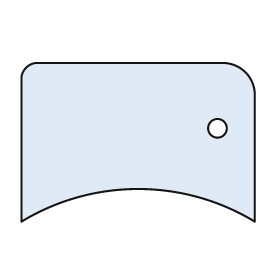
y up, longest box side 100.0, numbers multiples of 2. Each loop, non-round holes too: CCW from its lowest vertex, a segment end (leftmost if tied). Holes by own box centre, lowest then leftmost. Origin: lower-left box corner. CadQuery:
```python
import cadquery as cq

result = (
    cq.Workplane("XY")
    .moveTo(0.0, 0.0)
    .threePointArc((50.0, 14.0), (100.0, 0.0))
    .lineTo(100.0, 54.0)
    .threePointArc((96.0, 64.0), (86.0, 68.0))
    .lineTo(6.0, 68.0)
    .threePointArc((2.0, 66.0), (0.0, 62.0))
    .close()
    .moveTo(84.0, 40.0)
    .circle(4.0)
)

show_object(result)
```